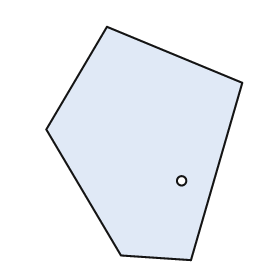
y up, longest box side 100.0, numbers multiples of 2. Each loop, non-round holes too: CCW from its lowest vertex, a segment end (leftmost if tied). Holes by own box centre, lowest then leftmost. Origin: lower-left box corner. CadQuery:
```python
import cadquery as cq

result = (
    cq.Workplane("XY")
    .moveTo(62.0, 0.0)
    .lineTo(84.0, 76.0)
    .lineTo(26.0, 100.0)
    .lineTo(0.0, 56.0)
    .lineTo(32.0, 2.0)
    .close()
    .moveTo(58.0, 34.0)
    .circle(2.0)
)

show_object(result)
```